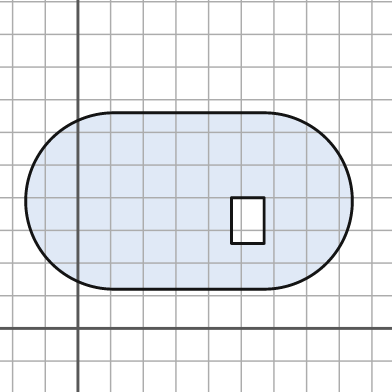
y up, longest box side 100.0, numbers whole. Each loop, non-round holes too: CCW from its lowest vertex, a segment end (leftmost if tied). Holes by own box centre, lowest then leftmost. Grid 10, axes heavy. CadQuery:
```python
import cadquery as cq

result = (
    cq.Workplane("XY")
    .moveTo(11.0, 12.0)
    .lineTo(57.0, 12.0)
    .threePointArc((84.0, 39.0), (57.0, 66.0))
    .lineTo(11.0, 66.0)
    .threePointArc((-16.0, 39.0), (11.0, 12.0))
    .close()
    .moveTo(47.0, 26.0)
    .lineTo(57.0, 26.0)
    .lineTo(57.0, 40.0)
    .lineTo(47.0, 40.0)
    .close()
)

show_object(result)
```